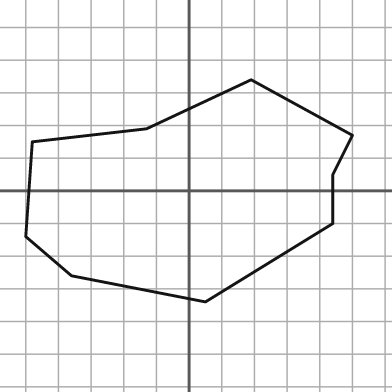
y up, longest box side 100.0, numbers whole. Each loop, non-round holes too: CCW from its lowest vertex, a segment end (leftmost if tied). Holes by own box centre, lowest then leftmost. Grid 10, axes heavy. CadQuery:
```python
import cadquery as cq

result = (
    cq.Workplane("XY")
    .moveTo(5.0, -34.0)
    .lineTo(44.0, -10.0)
    .lineTo(44.0, 5.0)
    .lineTo(50.0, 17.0)
    .lineTo(19.0, 34.0)
    .lineTo(-13.0, 19.0)
    .lineTo(-48.0, 15.0)
    .lineTo(-50.0, -14.0)
    .lineTo(-36.0, -26.0)
    .close()
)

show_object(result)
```